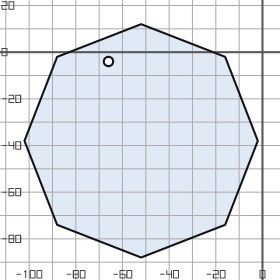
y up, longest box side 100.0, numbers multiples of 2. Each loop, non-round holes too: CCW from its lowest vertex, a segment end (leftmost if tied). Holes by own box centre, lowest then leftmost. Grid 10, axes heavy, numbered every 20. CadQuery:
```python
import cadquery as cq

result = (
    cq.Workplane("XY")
    .moveTo(-52.0, -88.0)
    .lineTo(-16.0, -74.0)
    .lineTo(-2.0, -38.0)
    .lineTo(-16.0, -2.0)
    .lineTo(-52.0, 12.0)
    .lineTo(-88.0, -2.0)
    .lineTo(-102.0, -38.0)
    .lineTo(-88.0, -74.0)
    .close()
    .moveTo(-66.0, -4.0)
    .circle(2.0)
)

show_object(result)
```